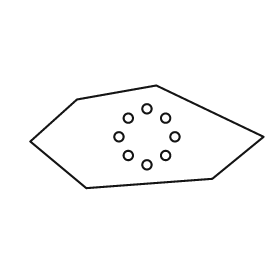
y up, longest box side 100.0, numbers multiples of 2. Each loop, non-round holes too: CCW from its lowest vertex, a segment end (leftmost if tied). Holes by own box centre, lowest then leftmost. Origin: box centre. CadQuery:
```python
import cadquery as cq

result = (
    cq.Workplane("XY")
    .moveTo(-26.0, -22.0)
    .lineTo(28.0, -18.0)
    .lineTo(50.0, 0.0)
    .lineTo(4.0, 22.0)
    .lineTo(-30.0, 16.0)
    .lineTo(-50.0, -2.0)
    .close()
    .moveTo(0.0, -12.0)
    .circle(2.0)
    .moveTo(-8.0, -8.0)
    .circle(2.0)
    .moveTo(8.0, -8.0)
    .circle(2.0)
    .moveTo(-12.0, 0.0)
    .circle(2.0)
    .moveTo(12.0, 0.0)
    .circle(2.0)
    .moveTo(-8.0, 8.0)
    .circle(2.0)
    .moveTo(8.0, 8.0)
    .circle(2.0)
    .moveTo(0.0, 12.0)
    .circle(2.0)
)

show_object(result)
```